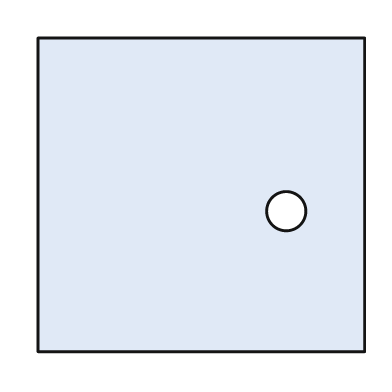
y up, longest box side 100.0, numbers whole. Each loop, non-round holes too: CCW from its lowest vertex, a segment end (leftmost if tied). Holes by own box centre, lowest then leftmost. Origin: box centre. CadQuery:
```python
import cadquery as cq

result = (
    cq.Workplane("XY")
    .moveTo(-50.0, -48.0)
    .lineTo(50.0, -48.0)
    .lineTo(50.0, 48.0)
    .lineTo(-50.0, 48.0)
    .close()
    .moveTo(26.0, -5.0)
    .circle(6.0)
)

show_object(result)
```